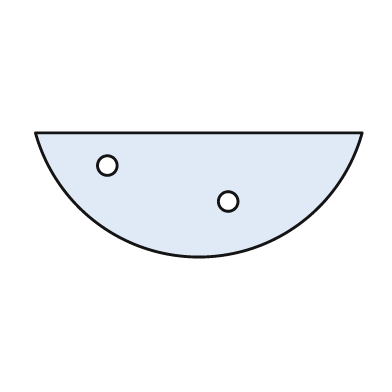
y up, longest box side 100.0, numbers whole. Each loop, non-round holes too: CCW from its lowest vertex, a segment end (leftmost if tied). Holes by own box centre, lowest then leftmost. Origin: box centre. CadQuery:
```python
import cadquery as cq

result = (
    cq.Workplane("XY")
    .moveTo(-50.0, 19.0)
    .threePointArc((0.0, -19.0), (50.0, 19.0))
    .close()
    .moveTo(9.0, -2.0)
    .circle(3.0)
    .moveTo(-28.0, 9.0)
    .circle(3.0)
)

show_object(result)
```